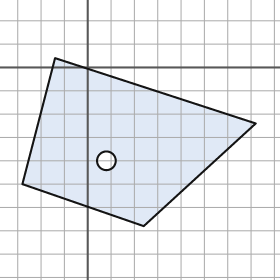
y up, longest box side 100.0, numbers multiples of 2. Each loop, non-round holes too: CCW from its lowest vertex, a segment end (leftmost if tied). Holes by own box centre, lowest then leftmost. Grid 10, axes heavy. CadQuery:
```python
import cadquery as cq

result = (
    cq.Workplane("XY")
    .moveTo(24.0, -68.0)
    .lineTo(72.0, -24.0)
    .lineTo(-14.0, 4.0)
    .lineTo(-28.0, -50.0)
    .close()
    .moveTo(8.0, -40.0)
    .circle(4.0)
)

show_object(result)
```